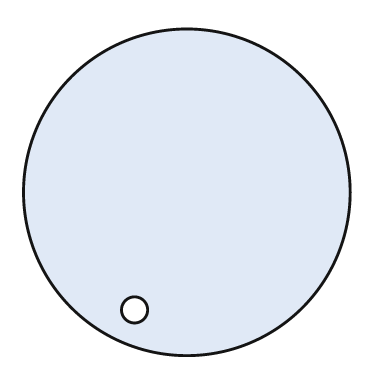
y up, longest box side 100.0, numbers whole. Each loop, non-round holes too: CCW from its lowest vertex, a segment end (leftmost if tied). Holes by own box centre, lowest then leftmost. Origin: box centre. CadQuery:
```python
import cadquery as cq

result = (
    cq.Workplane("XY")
    .moveTo(0.0, 0.0)
    .circle(50.0)
    .moveTo(-16.0, -36.0)
    .circle(4.0)
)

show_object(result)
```